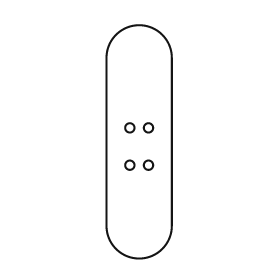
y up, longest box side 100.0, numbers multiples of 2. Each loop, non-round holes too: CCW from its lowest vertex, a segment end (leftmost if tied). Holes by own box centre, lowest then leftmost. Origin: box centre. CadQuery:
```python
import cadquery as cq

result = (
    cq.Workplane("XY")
    .moveTo(-14.0, -36.0)
    .threePointArc((0.0, -50.0), (14.0, -36.0))
    .lineTo(14.0, 36.0)
    .threePointArc((0.0, 50.0), (-14.0, 36.0))
    .close()
    .moveTo(-4.0, -10.0)
    .circle(2.0)
    .moveTo(4.0, -10.0)
    .circle(2.0)
    .moveTo(-4.0, 6.0)
    .circle(2.0)
    .moveTo(4.0, 6.0)
    .circle(2.0)
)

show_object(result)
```